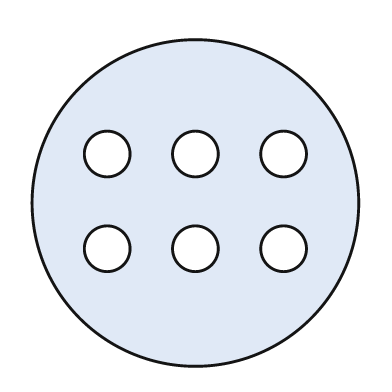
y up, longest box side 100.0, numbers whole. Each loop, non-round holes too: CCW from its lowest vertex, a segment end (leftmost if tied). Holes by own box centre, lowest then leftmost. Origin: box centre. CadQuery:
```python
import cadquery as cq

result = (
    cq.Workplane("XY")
    .moveTo(0.0, 0.0)
    .circle(50.0)
    .moveTo(-27.0, -14.0)
    .circle(7.0)
    .moveTo(0.0, -14.0)
    .circle(7.0)
    .moveTo(27.0, -14.0)
    .circle(7.0)
    .moveTo(-27.0, 15.0)
    .circle(7.0)
    .moveTo(0.0, 15.0)
    .circle(7.0)
    .moveTo(27.0, 15.0)
    .circle(7.0)
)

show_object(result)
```